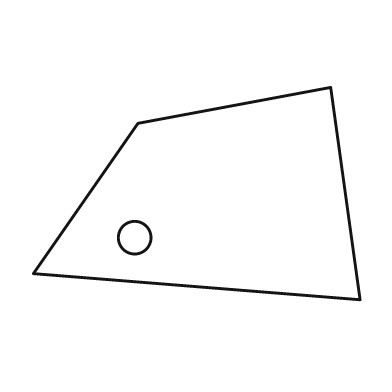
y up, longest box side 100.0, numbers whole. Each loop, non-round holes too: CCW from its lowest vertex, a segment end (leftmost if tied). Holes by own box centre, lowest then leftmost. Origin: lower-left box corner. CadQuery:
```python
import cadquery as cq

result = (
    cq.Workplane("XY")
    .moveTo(100.0, 0.0)
    .lineTo(91.0, 65.0)
    .lineTo(32.0, 54.0)
    .lineTo(0.0, 8.0)
    .close()
    .moveTo(31.0, 19.0)
    .circle(5.0)
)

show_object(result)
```